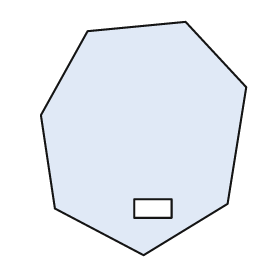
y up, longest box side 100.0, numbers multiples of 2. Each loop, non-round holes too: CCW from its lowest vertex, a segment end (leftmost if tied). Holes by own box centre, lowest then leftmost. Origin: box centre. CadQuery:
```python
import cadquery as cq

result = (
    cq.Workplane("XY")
    .moveTo(0.0, -50.0)
    .lineTo(36.0, -28.0)
    .lineTo(44.0, 22.0)
    .lineTo(18.0, 50.0)
    .lineTo(-24.0, 46.0)
    .lineTo(-44.0, 10.0)
    .lineTo(-38.0, -30.0)
    .close()
    .moveTo(-4.0, -34.0)
    .lineTo(12.0, -34.0)
    .lineTo(12.0, -26.0)
    .lineTo(-4.0, -26.0)
    .close()
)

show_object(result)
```